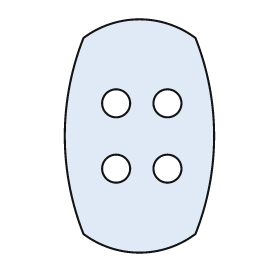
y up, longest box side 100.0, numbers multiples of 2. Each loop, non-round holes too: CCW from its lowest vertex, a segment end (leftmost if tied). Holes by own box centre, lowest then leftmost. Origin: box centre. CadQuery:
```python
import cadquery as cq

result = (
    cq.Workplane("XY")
    .moveTo(-24.0, -42.0)
    .threePointArc((0.0, -50.0), (24.0, -42.0))
    .threePointArc((32.0, 0.0), (24.0, 42.0))
    .threePointArc((0.0, 50.0), (-24.0, 42.0))
    .threePointArc((-32.0, 0.0), (-24.0, -42.0))
    .close()
    .moveTo(-10.0, -14.0)
    .circle(6.0)
    .moveTo(12.0, -14.0)
    .circle(6.0)
    .moveTo(-10.0, 14.0)
    .circle(6.0)
    .moveTo(12.0, 14.0)
    .circle(6.0)
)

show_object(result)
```